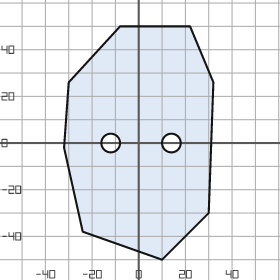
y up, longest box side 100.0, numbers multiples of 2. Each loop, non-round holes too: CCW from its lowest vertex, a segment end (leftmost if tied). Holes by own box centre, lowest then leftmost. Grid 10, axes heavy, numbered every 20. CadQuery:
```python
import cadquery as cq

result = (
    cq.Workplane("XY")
    .moveTo(10.0, -50.0)
    .lineTo(30.0, -30.0)
    .lineTo(32.0, 26.0)
    .lineTo(22.0, 50.0)
    .lineTo(-8.0, 50.0)
    .lineTo(-30.0, 26.0)
    .lineTo(-32.0, -2.0)
    .lineTo(-24.0, -38.0)
    .close()
    .moveTo(-12.0, 0.0)
    .circle(4.0)
    .moveTo(14.0, 0.0)
    .circle(4.0)
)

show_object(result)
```